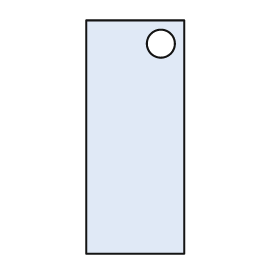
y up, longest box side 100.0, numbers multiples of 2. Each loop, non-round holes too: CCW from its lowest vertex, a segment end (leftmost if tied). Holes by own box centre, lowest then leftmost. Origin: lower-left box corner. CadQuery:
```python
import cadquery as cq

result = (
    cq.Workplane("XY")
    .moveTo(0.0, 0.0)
    .lineTo(42.0, 0.0)
    .lineTo(42.0, 100.0)
    .lineTo(0.0, 100.0)
    .close()
    .moveTo(32.0, 90.0)
    .circle(6.0)
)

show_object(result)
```